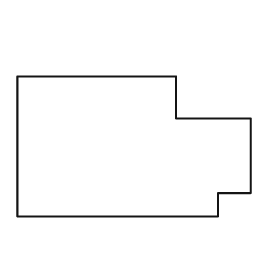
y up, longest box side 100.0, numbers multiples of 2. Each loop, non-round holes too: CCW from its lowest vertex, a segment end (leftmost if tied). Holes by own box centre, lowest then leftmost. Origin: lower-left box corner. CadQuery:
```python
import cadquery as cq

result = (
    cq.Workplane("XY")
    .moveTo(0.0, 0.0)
    .lineTo(86.0, 0.0)
    .lineTo(86.0, 10.0)
    .lineTo(100.0, 10.0)
    .lineTo(100.0, 42.0)
    .lineTo(68.0, 42.0)
    .lineTo(68.0, 60.0)
    .lineTo(0.0, 60.0)
    .close()
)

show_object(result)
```